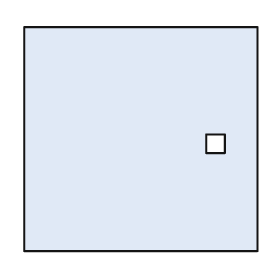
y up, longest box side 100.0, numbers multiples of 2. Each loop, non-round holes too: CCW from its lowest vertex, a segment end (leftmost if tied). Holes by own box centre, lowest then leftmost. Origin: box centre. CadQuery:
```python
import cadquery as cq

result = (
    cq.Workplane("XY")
    .moveTo(-50.0, -48.0)
    .lineTo(50.0, -48.0)
    .lineTo(50.0, 48.0)
    .lineTo(-50.0, 48.0)
    .close()
    .moveTo(28.0, -6.0)
    .lineTo(36.0, -6.0)
    .lineTo(36.0, 2.0)
    .lineTo(28.0, 2.0)
    .close()
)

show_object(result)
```